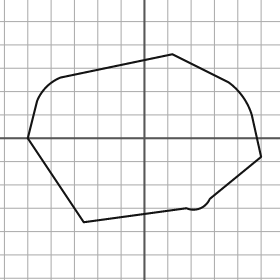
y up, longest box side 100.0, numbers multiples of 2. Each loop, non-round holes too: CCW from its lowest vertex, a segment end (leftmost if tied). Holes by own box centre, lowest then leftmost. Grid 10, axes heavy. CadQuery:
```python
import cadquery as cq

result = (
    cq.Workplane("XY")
    .moveTo(-26.0, -36.0)
    .lineTo(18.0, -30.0)
    .threePointArc((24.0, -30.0), (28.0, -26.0))
    .lineTo(50.0, -8.0)
    .lineTo(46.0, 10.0)
    .threePointArc((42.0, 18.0), (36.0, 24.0))
    .lineTo(12.0, 36.0)
    .lineTo(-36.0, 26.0)
    .threePointArc((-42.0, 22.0), (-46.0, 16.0))
    .lineTo(-50.0, 0.0)
    .close()
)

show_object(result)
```